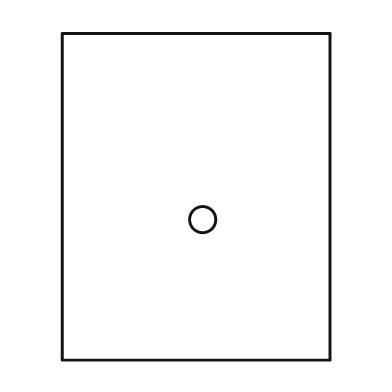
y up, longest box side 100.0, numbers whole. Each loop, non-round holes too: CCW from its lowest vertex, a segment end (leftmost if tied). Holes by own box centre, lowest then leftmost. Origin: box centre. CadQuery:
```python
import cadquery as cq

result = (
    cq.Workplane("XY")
    .moveTo(-41.0, -50.0)
    .lineTo(41.0, -50.0)
    .lineTo(41.0, 50.0)
    .lineTo(-41.0, 50.0)
    .close()
    .moveTo(2.0, -7.0)
    .circle(4.0)
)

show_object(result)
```